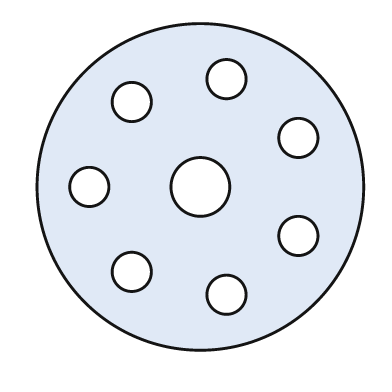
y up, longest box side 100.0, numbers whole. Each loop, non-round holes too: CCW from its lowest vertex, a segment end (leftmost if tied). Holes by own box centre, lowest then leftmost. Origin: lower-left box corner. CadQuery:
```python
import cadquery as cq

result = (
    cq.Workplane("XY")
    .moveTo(50.0, 50.0)
    .circle(50.0)
    .moveTo(58.0, 17.0)
    .circle(6.0)
    .moveTo(29.0, 24.0)
    .circle(6.0)
    .moveTo(80.0, 35.0)
    .circle(6.0)
    .moveTo(16.0, 50.0)
    .circle(6.0)
    .moveTo(50.0, 50.0)
    .circle(9.0)
    .moveTo(80.0, 65.0)
    .circle(6.0)
    .moveTo(29.0, 76.0)
    .circle(6.0)
    .moveTo(58.0, 83.0)
    .circle(6.0)
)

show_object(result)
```